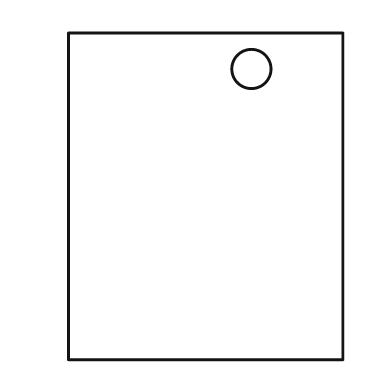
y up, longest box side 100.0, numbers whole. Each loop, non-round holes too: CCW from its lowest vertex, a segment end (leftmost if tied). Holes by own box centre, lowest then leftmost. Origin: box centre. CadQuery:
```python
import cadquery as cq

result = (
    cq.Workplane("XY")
    .moveTo(-42.0, -50.0)
    .lineTo(42.0, -50.0)
    .lineTo(42.0, 50.0)
    .lineTo(-42.0, 50.0)
    .close()
    .moveTo(14.0, 39.0)
    .circle(6.0)
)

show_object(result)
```